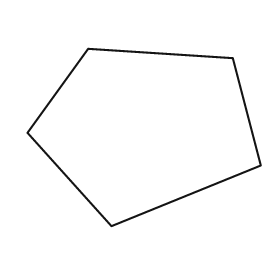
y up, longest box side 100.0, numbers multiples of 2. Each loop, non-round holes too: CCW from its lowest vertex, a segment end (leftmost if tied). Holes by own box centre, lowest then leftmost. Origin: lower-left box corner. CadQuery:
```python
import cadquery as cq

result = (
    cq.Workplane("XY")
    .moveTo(36.0, 0.0)
    .lineTo(100.0, 26.0)
    .lineTo(88.0, 72.0)
    .lineTo(26.0, 76.0)
    .lineTo(0.0, 40.0)
    .close()
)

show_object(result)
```